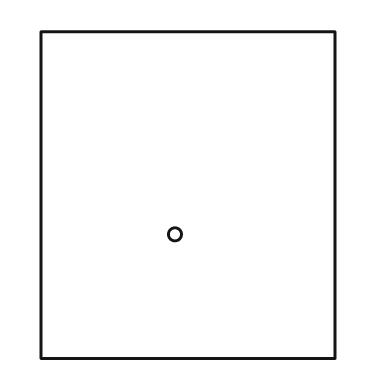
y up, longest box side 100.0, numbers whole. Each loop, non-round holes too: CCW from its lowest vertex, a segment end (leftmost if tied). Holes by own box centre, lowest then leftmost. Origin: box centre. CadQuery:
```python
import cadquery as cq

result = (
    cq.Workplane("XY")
    .moveTo(-45.0, -50.0)
    .lineTo(45.0, -50.0)
    .lineTo(45.0, 50.0)
    .lineTo(-45.0, 50.0)
    .close()
    .moveTo(-4.0, -12.0)
    .circle(2.0)
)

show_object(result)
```